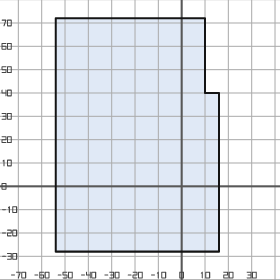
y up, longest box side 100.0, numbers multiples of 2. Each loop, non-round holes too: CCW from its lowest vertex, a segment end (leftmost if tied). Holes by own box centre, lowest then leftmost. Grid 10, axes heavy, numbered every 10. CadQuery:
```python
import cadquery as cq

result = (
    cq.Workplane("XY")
    .moveTo(-54.0, -28.0)
    .lineTo(16.0, -28.0)
    .lineTo(16.0, 40.0)
    .lineTo(10.0, 40.0)
    .lineTo(10.0, 72.0)
    .lineTo(-54.0, 72.0)
    .close()
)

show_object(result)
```